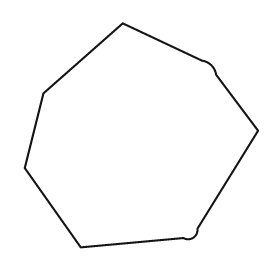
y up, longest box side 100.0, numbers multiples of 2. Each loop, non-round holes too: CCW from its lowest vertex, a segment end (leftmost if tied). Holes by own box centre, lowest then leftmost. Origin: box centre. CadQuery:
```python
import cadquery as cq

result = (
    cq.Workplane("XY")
    .moveTo(-26.0, -48.0)
    .lineTo(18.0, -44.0)
    .threePointArc((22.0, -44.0), (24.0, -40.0))
    .lineTo(50.0, 2.0)
    .lineTo(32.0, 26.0)
    .threePointArc((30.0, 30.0), (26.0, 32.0))
    .lineTo(-8.0, 48.0)
    .lineTo(-42.0, 18.0)
    .lineTo(-50.0, -14.0)
    .close()
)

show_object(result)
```